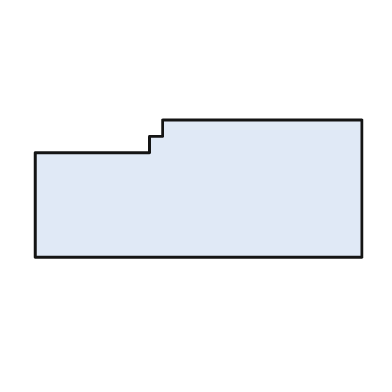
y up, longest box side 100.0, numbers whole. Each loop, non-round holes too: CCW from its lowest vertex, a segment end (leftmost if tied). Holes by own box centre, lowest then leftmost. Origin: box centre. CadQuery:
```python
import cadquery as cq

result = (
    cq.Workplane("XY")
    .moveTo(-50.0, -21.0)
    .lineTo(50.0, -21.0)
    .lineTo(50.0, 21.0)
    .lineTo(-11.0, 21.0)
    .lineTo(-11.0, 16.0)
    .lineTo(-15.0, 16.0)
    .lineTo(-15.0, 11.0)
    .lineTo(-50.0, 11.0)
    .close()
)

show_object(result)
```